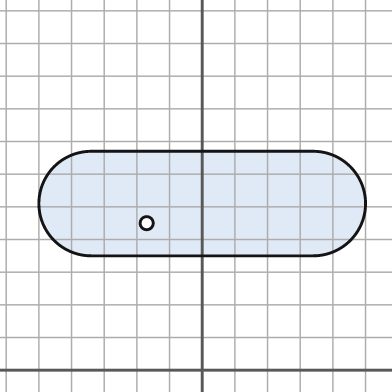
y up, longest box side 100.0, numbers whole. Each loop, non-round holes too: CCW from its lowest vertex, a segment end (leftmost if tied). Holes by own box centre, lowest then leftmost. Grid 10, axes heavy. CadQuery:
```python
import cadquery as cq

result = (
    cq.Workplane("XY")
    .moveTo(-34.0, 35.0)
    .lineTo(34.0, 35.0)
    .threePointArc((50.0, 51.0), (34.0, 67.0))
    .lineTo(-34.0, 67.0)
    .threePointArc((-50.0, 51.0), (-34.0, 35.0))
    .close()
    .moveTo(-17.0, 45.0)
    .circle(2.0)
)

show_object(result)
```